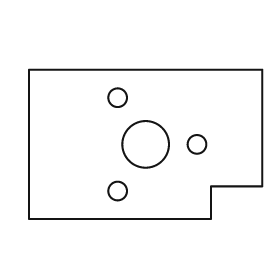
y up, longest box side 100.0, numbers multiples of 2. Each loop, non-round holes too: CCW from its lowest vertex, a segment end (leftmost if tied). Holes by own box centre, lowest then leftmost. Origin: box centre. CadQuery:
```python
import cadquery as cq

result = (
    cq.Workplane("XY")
    .moveTo(-50.0, -32.0)
    .lineTo(28.0, -32.0)
    .lineTo(28.0, -18.0)
    .lineTo(50.0, -18.0)
    .lineTo(50.0, 32.0)
    .lineTo(-50.0, 32.0)
    .close()
    .moveTo(-12.0, -20.0)
    .circle(4.0)
    .moveTo(0.0, 0.0)
    .circle(10.0)
    .moveTo(22.0, 0.0)
    .circle(4.0)
    .moveTo(-12.0, 20.0)
    .circle(4.0)
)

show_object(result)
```